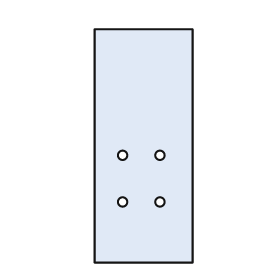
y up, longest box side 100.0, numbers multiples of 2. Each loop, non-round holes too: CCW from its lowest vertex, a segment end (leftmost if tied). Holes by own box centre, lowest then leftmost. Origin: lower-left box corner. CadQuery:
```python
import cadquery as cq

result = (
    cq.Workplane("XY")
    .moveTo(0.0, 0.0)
    .lineTo(42.0, 0.0)
    .lineTo(42.0, 100.0)
    .lineTo(0.0, 100.0)
    .close()
    .moveTo(12.0, 26.0)
    .circle(2.0)
    .moveTo(28.0, 26.0)
    .circle(2.0)
    .moveTo(12.0, 46.0)
    .circle(2.0)
    .moveTo(28.0, 46.0)
    .circle(2.0)
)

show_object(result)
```